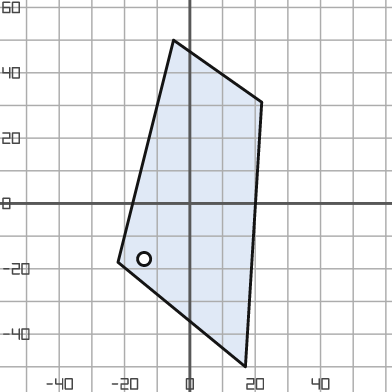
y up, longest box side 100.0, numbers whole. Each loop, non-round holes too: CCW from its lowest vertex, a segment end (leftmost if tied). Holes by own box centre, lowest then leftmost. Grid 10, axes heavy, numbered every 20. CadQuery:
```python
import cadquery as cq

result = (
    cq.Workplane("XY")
    .moveTo(17.0, -50.0)
    .lineTo(22.0, 31.0)
    .lineTo(-5.0, 50.0)
    .lineTo(-22.0, -18.0)
    .close()
    .moveTo(-14.0, -17.0)
    .circle(2.0)
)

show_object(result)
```